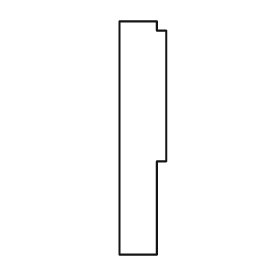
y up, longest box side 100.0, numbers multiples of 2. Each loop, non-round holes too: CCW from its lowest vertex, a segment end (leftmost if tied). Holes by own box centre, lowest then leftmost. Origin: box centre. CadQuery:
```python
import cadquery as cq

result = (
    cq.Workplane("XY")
    .moveTo(-10.0, -50.0)
    .lineTo(6.0, -50.0)
    .lineTo(6.0, -10.0)
    .lineTo(10.0, -10.0)
    .lineTo(10.0, 46.0)
    .lineTo(6.0, 46.0)
    .lineTo(6.0, 50.0)
    .lineTo(-10.0, 50.0)
    .close()
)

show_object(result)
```